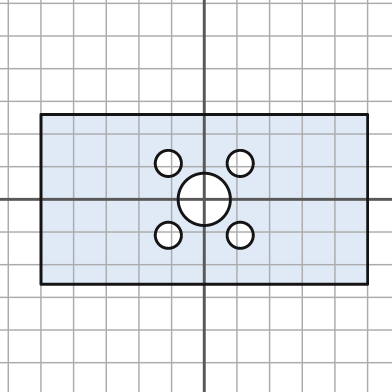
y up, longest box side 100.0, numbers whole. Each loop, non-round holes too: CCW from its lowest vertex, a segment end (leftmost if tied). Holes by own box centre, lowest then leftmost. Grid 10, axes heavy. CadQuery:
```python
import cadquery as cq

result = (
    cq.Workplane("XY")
    .moveTo(-50.0, -26.0)
    .lineTo(50.0, -26.0)
    .lineTo(50.0, 26.0)
    .lineTo(-50.0, 26.0)
    .close()
    .moveTo(-11.0, -11.0)
    .circle(4.0)
    .moveTo(11.0, -11.0)
    .circle(4.0)
    .moveTo(0.0, 0.0)
    .circle(8.0)
    .moveTo(-11.0, 11.0)
    .circle(4.0)
    .moveTo(11.0, 11.0)
    .circle(4.0)
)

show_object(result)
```